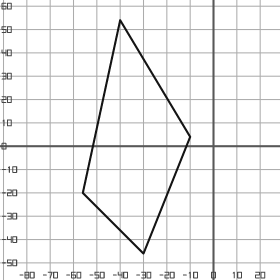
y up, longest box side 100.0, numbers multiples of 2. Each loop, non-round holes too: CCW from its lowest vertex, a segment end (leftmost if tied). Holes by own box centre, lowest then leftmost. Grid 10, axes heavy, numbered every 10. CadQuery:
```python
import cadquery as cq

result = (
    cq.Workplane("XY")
    .moveTo(-30.0, -46.0)
    .lineTo(-10.0, 4.0)
    .lineTo(-40.0, 54.0)
    .lineTo(-56.0, -20.0)
    .close()
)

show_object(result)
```